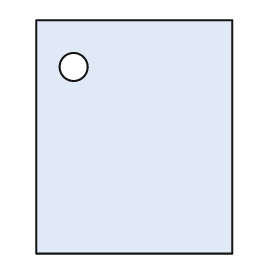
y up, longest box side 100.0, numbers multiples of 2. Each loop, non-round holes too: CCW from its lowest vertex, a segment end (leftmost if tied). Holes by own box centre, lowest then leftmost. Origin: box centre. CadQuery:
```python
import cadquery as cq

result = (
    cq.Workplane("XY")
    .moveTo(-42.0, -50.0)
    .lineTo(42.0, -50.0)
    .lineTo(42.0, 50.0)
    .lineTo(-42.0, 50.0)
    .close()
    .moveTo(-26.0, 30.0)
    .circle(6.0)
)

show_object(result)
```